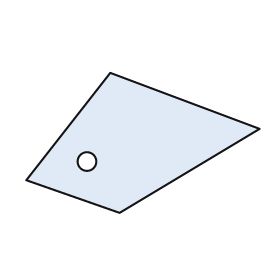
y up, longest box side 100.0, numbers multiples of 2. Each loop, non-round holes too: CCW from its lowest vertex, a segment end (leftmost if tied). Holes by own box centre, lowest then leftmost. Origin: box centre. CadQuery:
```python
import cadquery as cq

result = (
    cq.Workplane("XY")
    .moveTo(-10.0, -30.0)
    .lineTo(50.0, 6.0)
    .lineTo(-14.0, 30.0)
    .lineTo(-50.0, -16.0)
    .close()
    .moveTo(-24.0, -8.0)
    .circle(4.0)
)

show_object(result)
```